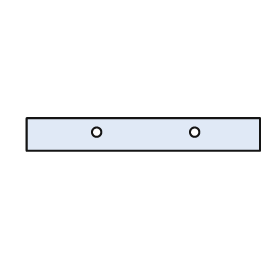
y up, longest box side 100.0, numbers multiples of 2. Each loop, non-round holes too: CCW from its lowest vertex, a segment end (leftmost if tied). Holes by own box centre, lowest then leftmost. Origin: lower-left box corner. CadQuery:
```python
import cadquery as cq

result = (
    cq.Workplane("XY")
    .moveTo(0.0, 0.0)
    .lineTo(100.0, 0.0)
    .lineTo(100.0, 14.0)
    .lineTo(0.0, 14.0)
    .close()
    .moveTo(30.0, 8.0)
    .circle(2.0)
    .moveTo(72.0, 8.0)
    .circle(2.0)
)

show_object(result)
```